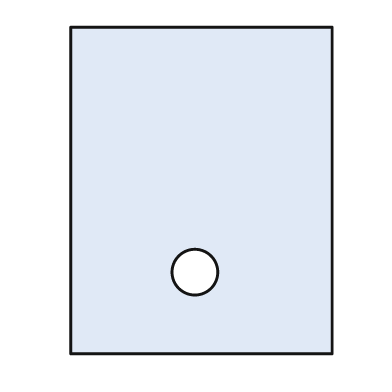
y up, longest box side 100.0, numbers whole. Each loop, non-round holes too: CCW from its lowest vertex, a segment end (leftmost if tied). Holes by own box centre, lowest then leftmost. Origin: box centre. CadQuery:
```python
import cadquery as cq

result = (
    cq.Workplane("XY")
    .moveTo(-40.0, -50.0)
    .lineTo(40.0, -50.0)
    .lineTo(40.0, 50.0)
    .lineTo(-40.0, 50.0)
    .close()
    .moveTo(-2.0, -25.0)
    .circle(7.0)
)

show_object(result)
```